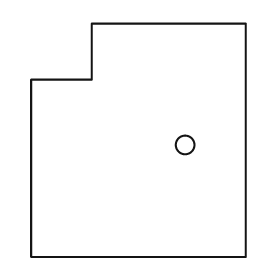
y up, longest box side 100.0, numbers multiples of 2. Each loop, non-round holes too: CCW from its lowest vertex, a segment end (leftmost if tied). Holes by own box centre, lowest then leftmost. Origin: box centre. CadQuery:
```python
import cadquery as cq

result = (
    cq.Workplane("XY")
    .moveTo(-46.0, -50.0)
    .lineTo(46.0, -50.0)
    .lineTo(46.0, 50.0)
    .lineTo(-20.0, 50.0)
    .lineTo(-20.0, 26.0)
    .lineTo(-46.0, 26.0)
    .close()
    .moveTo(20.0, -2.0)
    .circle(4.0)
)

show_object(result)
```